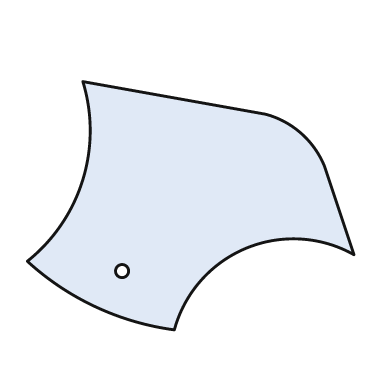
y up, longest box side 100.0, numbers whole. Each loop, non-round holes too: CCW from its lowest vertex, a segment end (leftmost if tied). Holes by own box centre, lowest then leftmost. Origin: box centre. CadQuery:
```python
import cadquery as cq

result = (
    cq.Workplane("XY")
    .moveTo(-5.0, -38.0)
    .threePointArc((17.0, -13.0), (50.0, -15.0))
    .lineTo(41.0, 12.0)
    .threePointArc((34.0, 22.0), (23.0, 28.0))
    .lineTo(-33.0, 38.0)
    .threePointArc((-33.0, 8.0), (-50.0, -17.0))
    .threePointArc((-29.0, -31.0), (-5.0, -38.0))
    .close()
    .moveTo(-21.0, -20.0)
    .circle(2.0)
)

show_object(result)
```